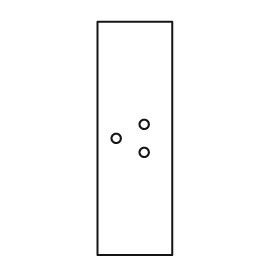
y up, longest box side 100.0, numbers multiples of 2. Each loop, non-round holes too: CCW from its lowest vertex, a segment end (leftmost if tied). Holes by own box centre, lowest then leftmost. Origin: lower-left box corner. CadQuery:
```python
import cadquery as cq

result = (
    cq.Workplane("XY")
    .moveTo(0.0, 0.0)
    .lineTo(32.0, 0.0)
    .lineTo(32.0, 100.0)
    .lineTo(0.0, 100.0)
    .close()
    .moveTo(20.0, 44.0)
    .circle(2.0)
    .moveTo(8.0, 50.0)
    .circle(2.0)
    .moveTo(20.0, 56.0)
    .circle(2.0)
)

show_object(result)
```